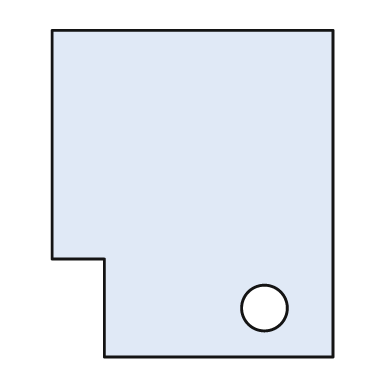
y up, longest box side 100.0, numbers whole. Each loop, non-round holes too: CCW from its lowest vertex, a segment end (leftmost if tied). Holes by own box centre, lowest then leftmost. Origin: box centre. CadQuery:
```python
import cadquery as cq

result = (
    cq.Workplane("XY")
    .moveTo(-27.0, -50.0)
    .lineTo(43.0, -50.0)
    .lineTo(43.0, 50.0)
    .lineTo(-43.0, 50.0)
    .lineTo(-43.0, -20.0)
    .lineTo(-27.0, -20.0)
    .close()
    .moveTo(22.0, -35.0)
    .circle(7.0)
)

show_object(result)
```